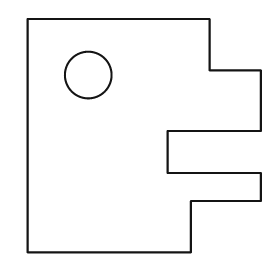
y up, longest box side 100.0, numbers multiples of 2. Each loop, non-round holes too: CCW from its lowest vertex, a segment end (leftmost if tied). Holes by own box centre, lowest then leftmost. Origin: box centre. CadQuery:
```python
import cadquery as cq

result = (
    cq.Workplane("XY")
    .moveTo(-50.0, -50.0)
    .lineTo(20.0, -50.0)
    .lineTo(20.0, -28.0)
    .lineTo(50.0, -28.0)
    .lineTo(50.0, -16.0)
    .lineTo(10.0, -16.0)
    .lineTo(10.0, 2.0)
    .lineTo(50.0, 2.0)
    .lineTo(50.0, 28.0)
    .lineTo(28.0, 28.0)
    .lineTo(28.0, 50.0)
    .lineTo(-50.0, 50.0)
    .close()
    .moveTo(-24.0, 26.0)
    .circle(10.0)
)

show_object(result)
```